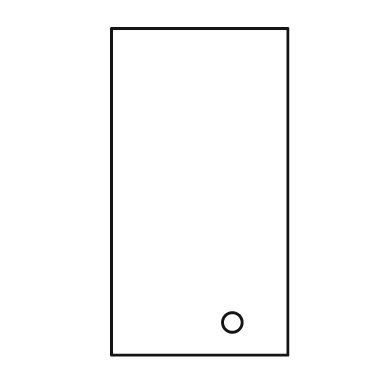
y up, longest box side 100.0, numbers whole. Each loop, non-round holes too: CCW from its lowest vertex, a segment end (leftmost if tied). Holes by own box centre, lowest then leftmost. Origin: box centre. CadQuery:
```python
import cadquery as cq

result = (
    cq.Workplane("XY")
    .moveTo(-27.0, -50.0)
    .lineTo(27.0, -50.0)
    .lineTo(27.0, 50.0)
    .lineTo(-27.0, 50.0)
    .close()
    .moveTo(10.0, -40.0)
    .circle(3.0)
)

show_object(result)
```